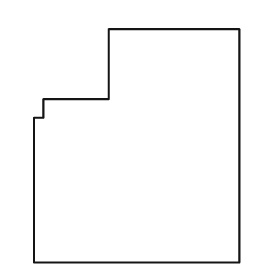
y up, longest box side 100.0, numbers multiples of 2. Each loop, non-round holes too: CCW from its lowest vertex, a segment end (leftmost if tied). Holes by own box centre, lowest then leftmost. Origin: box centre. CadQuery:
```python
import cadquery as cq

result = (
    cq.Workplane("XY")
    .moveTo(-44.0, -50.0)
    .lineTo(44.0, -50.0)
    .lineTo(44.0, 50.0)
    .lineTo(-12.0, 50.0)
    .lineTo(-12.0, 20.0)
    .lineTo(-40.0, 20.0)
    .lineTo(-40.0, 12.0)
    .lineTo(-44.0, 12.0)
    .close()
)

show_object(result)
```